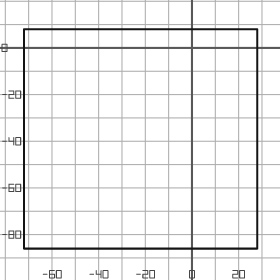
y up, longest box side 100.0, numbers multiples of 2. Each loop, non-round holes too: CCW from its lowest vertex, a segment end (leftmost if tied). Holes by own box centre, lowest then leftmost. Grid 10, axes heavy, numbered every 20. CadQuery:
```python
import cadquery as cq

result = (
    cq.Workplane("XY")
    .moveTo(-72.0, -86.0)
    .lineTo(28.0, -86.0)
    .lineTo(28.0, 8.0)
    .lineTo(-72.0, 8.0)
    .close()
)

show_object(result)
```